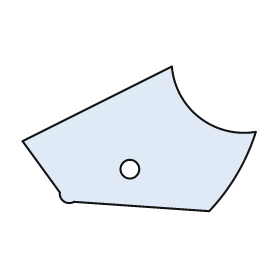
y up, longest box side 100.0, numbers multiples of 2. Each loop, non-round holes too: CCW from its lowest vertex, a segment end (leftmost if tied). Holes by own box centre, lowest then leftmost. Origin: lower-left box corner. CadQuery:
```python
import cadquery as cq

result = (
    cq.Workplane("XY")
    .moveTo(80.0, 0.0)
    .threePointArc((92.0, 16.0), (100.0, 34.0))
    .threePointArc((76.0, 40.0), (64.0, 62.0))
    .lineTo(0.0, 30.0)
    .lineTo(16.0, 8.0)
    .threePointArc((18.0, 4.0), (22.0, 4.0))
    .close()
    .moveTo(46.0, 18.0)
    .circle(4.0)
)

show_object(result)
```